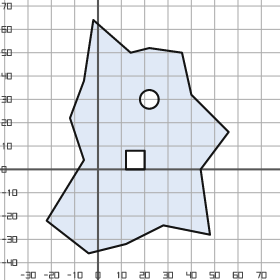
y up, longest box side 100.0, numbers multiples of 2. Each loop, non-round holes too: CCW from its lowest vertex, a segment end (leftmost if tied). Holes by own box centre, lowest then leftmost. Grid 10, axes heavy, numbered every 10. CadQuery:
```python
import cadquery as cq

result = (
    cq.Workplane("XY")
    .moveTo(-4.0, -36.0)
    .lineTo(12.0, -32.0)
    .lineTo(28.0, -24.0)
    .lineTo(48.0, -28.0)
    .lineTo(44.0, 0.0)
    .lineTo(56.0, 16.0)
    .lineTo(40.0, 32.0)
    .lineTo(36.0, 50.0)
    .lineTo(22.0, 52.0)
    .lineTo(14.0, 50.0)
    .lineTo(-2.0, 64.0)
    .lineTo(-6.0, 38.0)
    .lineTo(-12.0, 22.0)
    .lineTo(-6.0, 4.0)
    .lineTo(-22.0, -22.0)
    .close()
    .moveTo(12.0, 0.0)
    .lineTo(20.0, 0.0)
    .lineTo(20.0, 8.0)
    .lineTo(12.0, 8.0)
    .close()
    .moveTo(22.0, 30.0)
    .circle(4.0)
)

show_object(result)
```